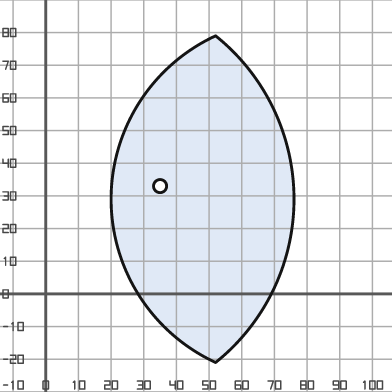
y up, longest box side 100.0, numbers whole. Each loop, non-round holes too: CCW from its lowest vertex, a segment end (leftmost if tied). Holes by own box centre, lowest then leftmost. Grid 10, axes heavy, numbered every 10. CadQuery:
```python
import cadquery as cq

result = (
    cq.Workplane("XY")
    .moveTo(52.0, -21.0)
    .threePointArc((76.0, 29.0), (52.0, 79.0))
    .threePointArc((20.0, 29.0), (52.0, -21.0))
    .close()
    .moveTo(35.0, 33.0)
    .circle(2.0)
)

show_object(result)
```